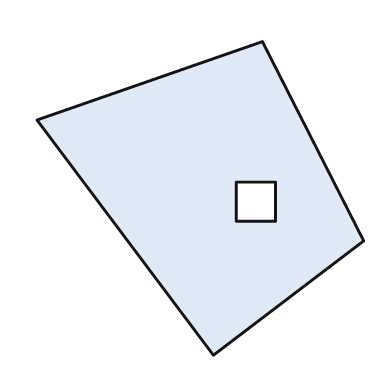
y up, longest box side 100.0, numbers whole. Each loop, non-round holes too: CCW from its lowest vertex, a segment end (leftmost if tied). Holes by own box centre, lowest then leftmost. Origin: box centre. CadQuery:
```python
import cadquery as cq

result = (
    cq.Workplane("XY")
    .moveTo(4.0, -48.0)
    .lineTo(50.0, -13.0)
    .lineTo(19.0, 48.0)
    .lineTo(-50.0, 24.0)
    .close()
    .moveTo(11.0, -7.0)
    .lineTo(23.0, -7.0)
    .lineTo(23.0, 5.0)
    .lineTo(11.0, 5.0)
    .close()
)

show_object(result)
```